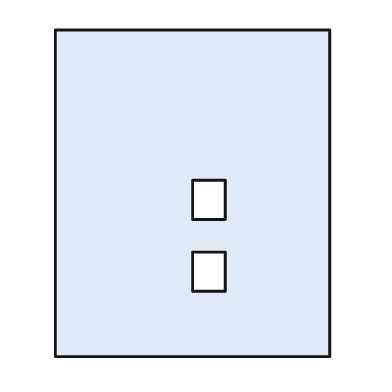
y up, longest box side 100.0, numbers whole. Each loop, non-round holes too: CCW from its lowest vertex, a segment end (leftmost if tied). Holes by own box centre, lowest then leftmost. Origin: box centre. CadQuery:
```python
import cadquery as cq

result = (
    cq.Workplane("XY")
    .moveTo(-42.0, -50.0)
    .lineTo(42.0, -50.0)
    .lineTo(42.0, 50.0)
    .lineTo(-42.0, 50.0)
    .close()
    .moveTo(0.0, -30.0)
    .lineTo(10.0, -30.0)
    .lineTo(10.0, -18.0)
    .lineTo(0.0, -18.0)
    .close()
    .moveTo(0.0, -8.0)
    .lineTo(10.0, -8.0)
    .lineTo(10.0, 4.0)
    .lineTo(0.0, 4.0)
    .close()
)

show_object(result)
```